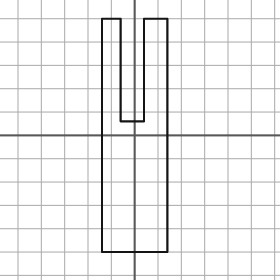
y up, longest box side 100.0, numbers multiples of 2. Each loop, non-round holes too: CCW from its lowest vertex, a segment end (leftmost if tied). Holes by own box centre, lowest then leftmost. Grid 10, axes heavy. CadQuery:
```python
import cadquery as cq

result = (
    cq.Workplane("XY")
    .moveTo(-14.0, -50.0)
    .lineTo(14.0, -50.0)
    .lineTo(14.0, 50.0)
    .lineTo(4.0, 50.0)
    .lineTo(4.0, 6.0)
    .lineTo(-6.0, 6.0)
    .lineTo(-6.0, 50.0)
    .lineTo(-14.0, 50.0)
    .close()
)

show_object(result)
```